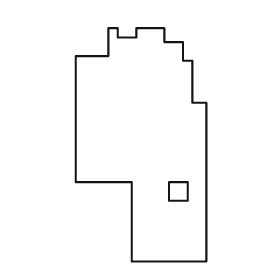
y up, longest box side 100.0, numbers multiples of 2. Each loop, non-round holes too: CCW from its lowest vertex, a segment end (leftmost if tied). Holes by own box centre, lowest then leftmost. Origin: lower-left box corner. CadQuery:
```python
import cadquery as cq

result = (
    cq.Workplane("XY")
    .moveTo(24.0, 0.0)
    .lineTo(56.0, 0.0)
    .lineTo(56.0, 68.0)
    .lineTo(50.0, 68.0)
    .lineTo(50.0, 86.0)
    .lineTo(46.0, 86.0)
    .lineTo(46.0, 94.0)
    .lineTo(38.0, 94.0)
    .lineTo(38.0, 100.0)
    .lineTo(26.0, 100.0)
    .lineTo(26.0, 96.0)
    .lineTo(18.0, 96.0)
    .lineTo(18.0, 100.0)
    .lineTo(14.0, 100.0)
    .lineTo(14.0, 88.0)
    .lineTo(0.0, 88.0)
    .lineTo(0.0, 34.0)
    .lineTo(24.0, 34.0)
    .close()
    .moveTo(40.0, 26.0)
    .lineTo(48.0, 26.0)
    .lineTo(48.0, 34.0)
    .lineTo(40.0, 34.0)
    .close()
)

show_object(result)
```